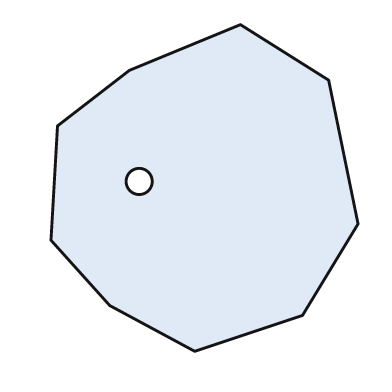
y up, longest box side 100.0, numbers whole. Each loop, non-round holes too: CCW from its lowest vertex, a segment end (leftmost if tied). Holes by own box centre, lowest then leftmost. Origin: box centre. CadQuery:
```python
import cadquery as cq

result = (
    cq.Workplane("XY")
    .moveTo(-3.0, -50.0)
    .lineTo(30.0, -39.0)
    .lineTo(47.0, -11.0)
    .lineTo(38.0, 33.0)
    .lineTo(11.0, 50.0)
    .lineTo(-23.0, 36.0)
    .lineTo(-45.0, 19.0)
    .lineTo(-47.0, -16.0)
    .lineTo(-29.0, -36.0)
    .close()
    .moveTo(-20.0, 2.0)
    .circle(4.0)
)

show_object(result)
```